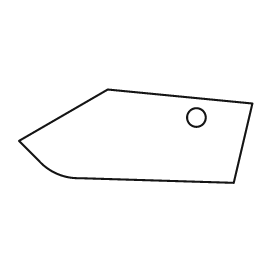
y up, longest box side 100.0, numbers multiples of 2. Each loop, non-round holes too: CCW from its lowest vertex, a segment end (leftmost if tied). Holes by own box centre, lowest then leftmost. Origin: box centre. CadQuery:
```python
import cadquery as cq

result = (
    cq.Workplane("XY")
    .moveTo(42.0, -20.0)
    .lineTo(50.0, 14.0)
    .lineTo(-12.0, 20.0)
    .lineTo(-50.0, -2.0)
    .lineTo(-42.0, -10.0)
    .threePointArc((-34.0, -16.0), (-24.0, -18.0))
    .close()
    .moveTo(26.0, 8.0)
    .circle(4.0)
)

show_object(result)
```